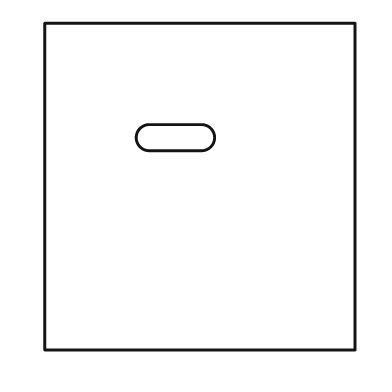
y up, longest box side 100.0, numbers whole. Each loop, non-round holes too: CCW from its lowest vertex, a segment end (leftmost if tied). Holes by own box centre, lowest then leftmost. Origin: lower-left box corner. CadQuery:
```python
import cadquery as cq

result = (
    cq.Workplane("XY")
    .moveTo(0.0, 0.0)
    .lineTo(95.0, 0.0)
    .lineTo(95.0, 100.0)
    .lineTo(0.0, 100.0)
    .close()
    .moveTo(32.0, 61.0)
    .lineTo(48.0, 61.0)
    .threePointArc((52.0, 65.0), (48.0, 69.0))
    .lineTo(32.0, 69.0)
    .threePointArc((28.0, 65.0), (32.0, 61.0))
    .close()
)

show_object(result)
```